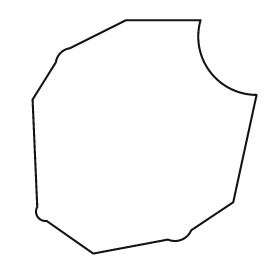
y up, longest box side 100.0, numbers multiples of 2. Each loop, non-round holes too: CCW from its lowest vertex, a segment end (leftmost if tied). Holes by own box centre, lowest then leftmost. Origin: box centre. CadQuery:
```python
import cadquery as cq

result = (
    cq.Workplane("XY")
    .moveTo(-22.0, -50.0)
    .lineTo(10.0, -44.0)
    .threePointArc((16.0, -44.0), (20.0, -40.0))
    .lineTo(38.0, -28.0)
    .lineTo(48.0, 18.0)
    .threePointArc((28.0, 28.0), (24.0, 50.0))
    .lineTo(-8.0, 50.0)
    .lineTo(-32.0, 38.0)
    .threePointArc((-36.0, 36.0), (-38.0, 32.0))
    .lineTo(-48.0, 16.0)
    .lineTo(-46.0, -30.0)
    .threePointArc((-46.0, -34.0), (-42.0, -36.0))
    .close()
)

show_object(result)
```